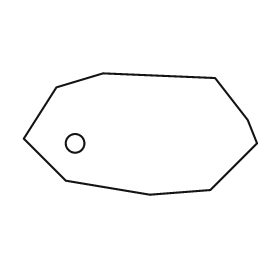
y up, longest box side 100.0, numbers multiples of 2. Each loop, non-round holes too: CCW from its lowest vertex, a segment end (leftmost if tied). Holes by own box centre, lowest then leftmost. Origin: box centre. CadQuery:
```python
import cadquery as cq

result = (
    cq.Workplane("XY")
    .moveTo(4.0, -26.0)
    .lineTo(30.0, -24.0)
    .lineTo(50.0, -4.0)
    .lineTo(46.0, 6.0)
    .lineTo(32.0, 24.0)
    .lineTo(-16.0, 26.0)
    .lineTo(-36.0, 20.0)
    .lineTo(-50.0, -2.0)
    .lineTo(-32.0, -20.0)
    .close()
    .moveTo(-28.0, -4.0)
    .circle(4.0)
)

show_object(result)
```